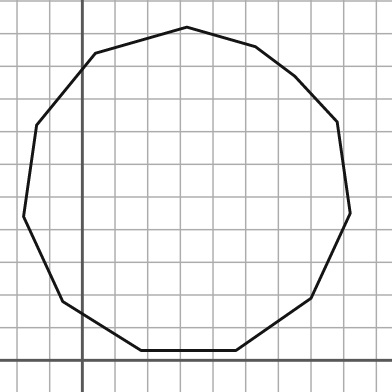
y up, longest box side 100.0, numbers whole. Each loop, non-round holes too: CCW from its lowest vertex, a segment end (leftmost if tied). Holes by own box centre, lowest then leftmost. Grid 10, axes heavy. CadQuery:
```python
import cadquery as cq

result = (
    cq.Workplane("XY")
    .moveTo(18.0, 3.0)
    .lineTo(47.0, 3.0)
    .lineTo(70.0, 19.0)
    .lineTo(82.0, 45.0)
    .lineTo(78.0, 73.0)
    .lineTo(65.0, 87.0)
    .lineTo(53.0, 96.0)
    .lineTo(32.0, 102.0)
    .lineTo(4.0, 94.0)
    .lineTo(-14.0, 72.0)
    .lineTo(-18.0, 44.0)
    .lineTo(-6.0, 18.0)
    .close()
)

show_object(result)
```